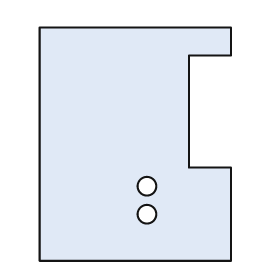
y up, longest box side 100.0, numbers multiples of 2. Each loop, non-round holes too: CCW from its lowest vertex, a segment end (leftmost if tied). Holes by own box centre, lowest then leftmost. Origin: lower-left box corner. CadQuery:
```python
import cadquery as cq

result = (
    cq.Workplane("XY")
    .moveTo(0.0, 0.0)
    .lineTo(82.0, 0.0)
    .lineTo(82.0, 40.0)
    .lineTo(64.0, 40.0)
    .lineTo(64.0, 88.0)
    .lineTo(82.0, 88.0)
    .lineTo(82.0, 100.0)
    .lineTo(0.0, 100.0)
    .close()
    .moveTo(46.0, 20.0)
    .circle(4.0)
    .moveTo(46.0, 32.0)
    .circle(4.0)
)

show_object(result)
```